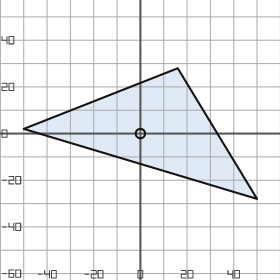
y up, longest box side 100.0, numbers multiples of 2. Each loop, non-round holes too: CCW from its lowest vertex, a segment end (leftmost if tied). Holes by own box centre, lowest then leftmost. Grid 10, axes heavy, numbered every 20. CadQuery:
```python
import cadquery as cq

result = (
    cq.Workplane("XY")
    .moveTo(50.0, -28.0)
    .lineTo(16.0, 28.0)
    .lineTo(-50.0, 2.0)
    .close()
    .moveTo(0.0, 0.0)
    .circle(2.0)
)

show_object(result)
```